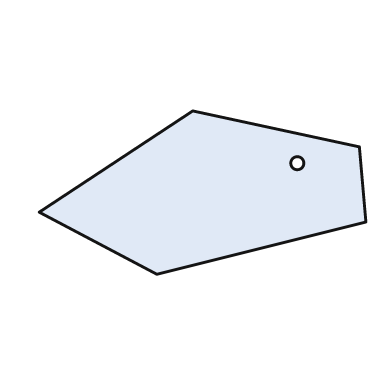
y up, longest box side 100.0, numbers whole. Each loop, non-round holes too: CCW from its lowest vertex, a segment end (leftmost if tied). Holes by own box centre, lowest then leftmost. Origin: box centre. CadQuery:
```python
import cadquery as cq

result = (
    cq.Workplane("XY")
    .moveTo(-14.0, -25.0)
    .lineTo(50.0, -9.0)
    .lineTo(48.0, 14.0)
    .lineTo(-3.0, 25.0)
    .lineTo(-50.0, -6.0)
    .close()
    .moveTo(29.0, 9.0)
    .circle(2.0)
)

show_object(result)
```